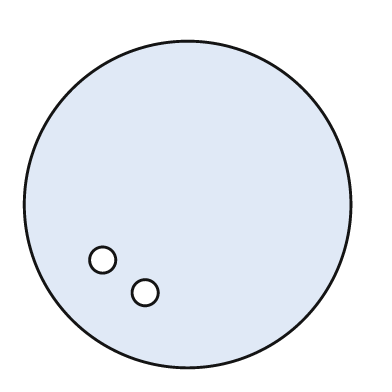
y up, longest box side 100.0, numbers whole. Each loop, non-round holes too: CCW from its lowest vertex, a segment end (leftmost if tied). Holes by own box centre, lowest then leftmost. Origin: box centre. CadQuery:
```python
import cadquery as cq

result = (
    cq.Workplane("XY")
    .moveTo(0.0, 0.0)
    .circle(50.0)
    .moveTo(-13.0, -27.0)
    .circle(4.0)
    .moveTo(-26.0, -17.0)
    .circle(4.0)
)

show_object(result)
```